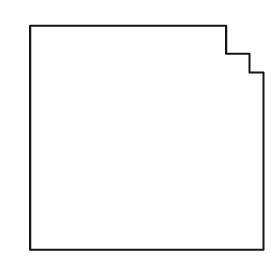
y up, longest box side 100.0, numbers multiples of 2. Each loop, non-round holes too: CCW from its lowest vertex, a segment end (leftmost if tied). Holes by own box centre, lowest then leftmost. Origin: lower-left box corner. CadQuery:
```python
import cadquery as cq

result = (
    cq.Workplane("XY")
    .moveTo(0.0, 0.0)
    .lineTo(100.0, 0.0)
    .lineTo(100.0, 76.0)
    .lineTo(94.0, 76.0)
    .lineTo(94.0, 84.0)
    .lineTo(84.0, 84.0)
    .lineTo(84.0, 96.0)
    .lineTo(0.0, 96.0)
    .close()
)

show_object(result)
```